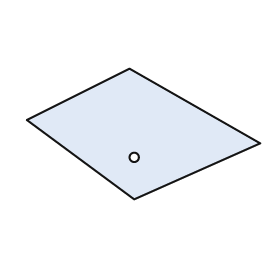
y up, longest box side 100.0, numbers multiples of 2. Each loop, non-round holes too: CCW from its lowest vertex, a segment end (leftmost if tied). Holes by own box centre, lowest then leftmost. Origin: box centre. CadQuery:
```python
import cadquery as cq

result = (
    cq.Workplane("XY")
    .moveTo(-4.0, -28.0)
    .lineTo(50.0, -4.0)
    .lineTo(-6.0, 28.0)
    .lineTo(-50.0, 6.0)
    .close()
    .moveTo(-4.0, -10.0)
    .circle(2.0)
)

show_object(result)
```